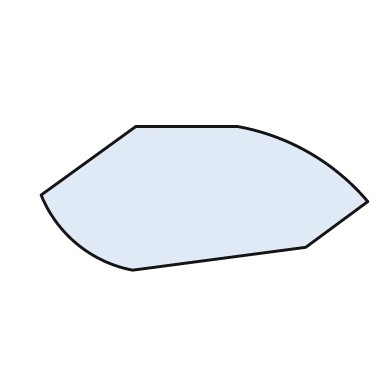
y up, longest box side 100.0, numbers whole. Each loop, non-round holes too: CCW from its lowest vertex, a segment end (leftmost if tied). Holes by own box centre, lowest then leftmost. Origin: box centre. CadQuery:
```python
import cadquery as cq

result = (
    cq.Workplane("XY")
    .moveTo(-22.0, -22.0)
    .lineTo(31.0, -15.0)
    .lineTo(50.0, -1.0)
    .threePointArc((32.0, 14.0), (10.0, 22.0))
    .lineTo(-21.0, 22.0)
    .lineTo(-50.0, 1.0)
    .threePointArc((-39.0, -14.0), (-22.0, -22.0))
    .close()
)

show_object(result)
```